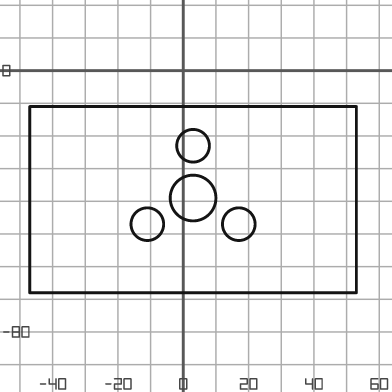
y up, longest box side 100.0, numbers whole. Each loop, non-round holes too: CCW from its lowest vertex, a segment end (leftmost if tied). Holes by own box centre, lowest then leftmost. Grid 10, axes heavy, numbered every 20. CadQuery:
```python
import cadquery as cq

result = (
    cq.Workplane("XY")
    .moveTo(-47.0, -68.0)
    .lineTo(53.0, -68.0)
    .lineTo(53.0, -11.0)
    .lineTo(-47.0, -11.0)
    .close()
    .moveTo(-11.0, -47.0)
    .circle(5.0)
    .moveTo(17.0, -47.0)
    .circle(5.0)
    .moveTo(3.0, -39.0)
    .circle(7.0)
    .moveTo(3.0, -23.0)
    .circle(5.0)
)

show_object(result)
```